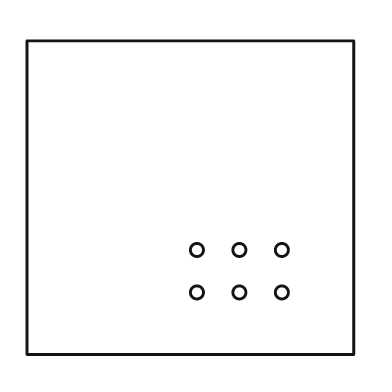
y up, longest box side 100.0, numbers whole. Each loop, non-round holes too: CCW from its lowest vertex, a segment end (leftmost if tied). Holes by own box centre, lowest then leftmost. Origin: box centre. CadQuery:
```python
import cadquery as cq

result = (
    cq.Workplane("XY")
    .moveTo(-50.0, -48.0)
    .lineTo(50.0, -48.0)
    .lineTo(50.0, 48.0)
    .lineTo(-50.0, 48.0)
    .close()
    .moveTo(2.0, -29.0)
    .circle(2.0)
    .moveTo(15.0, -29.0)
    .circle(2.0)
    .moveTo(28.0, -29.0)
    .circle(2.0)
    .moveTo(2.0, -16.0)
    .circle(2.0)
    .moveTo(15.0, -16.0)
    .circle(2.0)
    .moveTo(28.0, -16.0)
    .circle(2.0)
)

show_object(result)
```